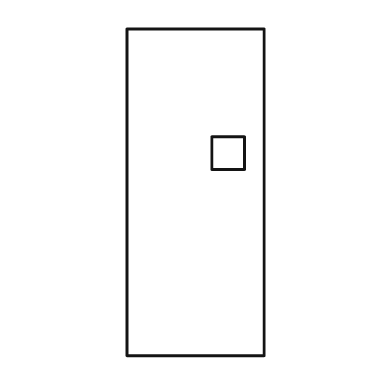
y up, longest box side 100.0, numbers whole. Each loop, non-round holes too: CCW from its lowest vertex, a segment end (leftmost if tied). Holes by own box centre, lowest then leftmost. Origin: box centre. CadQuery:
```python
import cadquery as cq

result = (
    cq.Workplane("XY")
    .moveTo(-21.0, -50.0)
    .lineTo(21.0, -50.0)
    .lineTo(21.0, 50.0)
    .lineTo(-21.0, 50.0)
    .close()
    .moveTo(5.0, 7.0)
    .lineTo(15.0, 7.0)
    .lineTo(15.0, 17.0)
    .lineTo(5.0, 17.0)
    .close()
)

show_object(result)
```